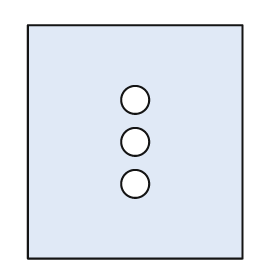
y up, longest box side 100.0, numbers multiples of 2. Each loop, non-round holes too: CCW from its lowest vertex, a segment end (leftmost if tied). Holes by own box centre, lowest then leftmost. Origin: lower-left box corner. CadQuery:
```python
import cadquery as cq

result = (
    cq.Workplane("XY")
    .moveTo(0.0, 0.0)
    .lineTo(92.0, 0.0)
    .lineTo(92.0, 100.0)
    .lineTo(0.0, 100.0)
    .close()
    .moveTo(46.0, 32.0)
    .circle(6.0)
    .moveTo(46.0, 50.0)
    .circle(6.0)
    .moveTo(46.0, 68.0)
    .circle(6.0)
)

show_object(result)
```